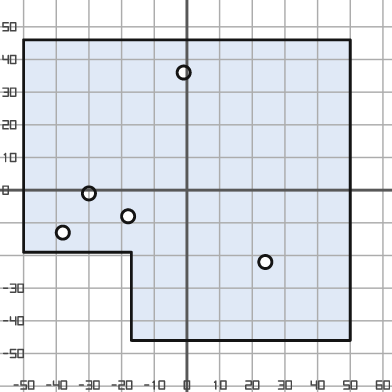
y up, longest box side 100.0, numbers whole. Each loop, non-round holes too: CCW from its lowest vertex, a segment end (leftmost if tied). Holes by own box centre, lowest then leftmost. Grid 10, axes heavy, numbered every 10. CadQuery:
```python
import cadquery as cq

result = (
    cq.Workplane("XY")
    .moveTo(-17.0, -46.0)
    .lineTo(50.0, -46.0)
    .lineTo(50.0, 46.0)
    .lineTo(-50.0, 46.0)
    .lineTo(-50.0, -19.0)
    .lineTo(-17.0, -19.0)
    .close()
    .moveTo(24.0, -22.0)
    .circle(2.0)
    .moveTo(-38.0, -13.0)
    .circle(2.0)
    .moveTo(-18.0, -8.0)
    .circle(2.0)
    .moveTo(-30.0, -1.0)
    .circle(2.0)
    .moveTo(-1.0, 36.0)
    .circle(2.0)
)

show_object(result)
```